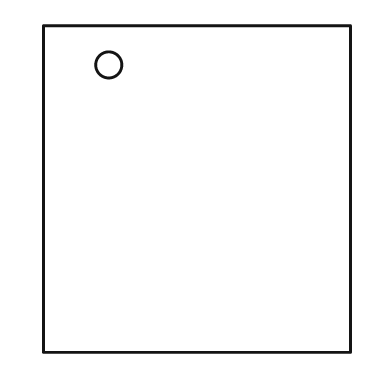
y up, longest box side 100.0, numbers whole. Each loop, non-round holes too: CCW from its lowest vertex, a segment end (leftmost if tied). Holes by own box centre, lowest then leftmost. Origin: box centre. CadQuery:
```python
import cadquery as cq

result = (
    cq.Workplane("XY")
    .moveTo(-47.0, -50.0)
    .lineTo(47.0, -50.0)
    .lineTo(47.0, 50.0)
    .lineTo(-47.0, 50.0)
    .close()
    .moveTo(-27.0, 38.0)
    .circle(4.0)
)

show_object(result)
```